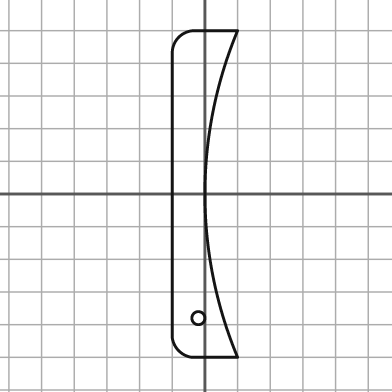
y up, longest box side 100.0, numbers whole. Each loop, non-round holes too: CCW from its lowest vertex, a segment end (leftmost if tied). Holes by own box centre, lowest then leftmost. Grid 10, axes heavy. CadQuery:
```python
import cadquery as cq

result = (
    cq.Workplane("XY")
    .moveTo(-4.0, -50.0)
    .lineTo(10.0, -50.0)
    .threePointArc((0.0, 0.0), (10.0, 50.0))
    .lineTo(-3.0, 50.0)
    .threePointArc((-8.0, 48.0), (-10.0, 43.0))
    .lineTo(-10.0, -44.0)
    .threePointArc((-8.0, -48.0), (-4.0, -50.0))
    .close()
    .moveTo(-2.0, -38.0)
    .circle(2.0)
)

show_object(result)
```